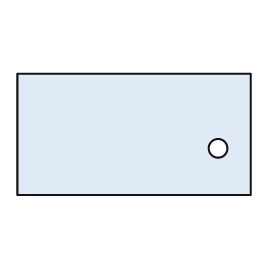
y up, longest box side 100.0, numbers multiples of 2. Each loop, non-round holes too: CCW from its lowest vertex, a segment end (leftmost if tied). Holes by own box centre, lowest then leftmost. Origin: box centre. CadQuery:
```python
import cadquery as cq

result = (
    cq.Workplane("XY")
    .moveTo(-50.0, -26.0)
    .lineTo(50.0, -26.0)
    .lineTo(50.0, 26.0)
    .lineTo(-50.0, 26.0)
    .close()
    .moveTo(36.0, -6.0)
    .circle(4.0)
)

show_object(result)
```